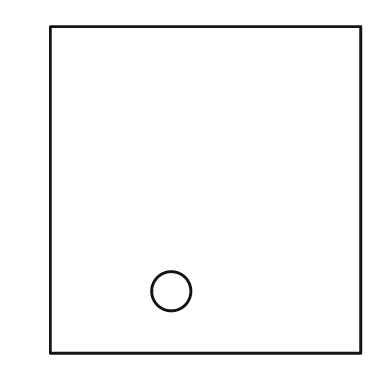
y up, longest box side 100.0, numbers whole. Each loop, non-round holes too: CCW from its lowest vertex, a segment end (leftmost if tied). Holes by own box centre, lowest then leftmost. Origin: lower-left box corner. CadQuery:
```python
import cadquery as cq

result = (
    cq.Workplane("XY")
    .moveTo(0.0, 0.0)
    .lineTo(95.0, 0.0)
    .lineTo(95.0, 100.0)
    .lineTo(0.0, 100.0)
    .close()
    .moveTo(37.0, 19.0)
    .circle(6.0)
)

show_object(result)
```